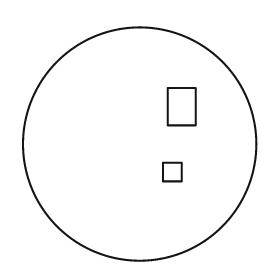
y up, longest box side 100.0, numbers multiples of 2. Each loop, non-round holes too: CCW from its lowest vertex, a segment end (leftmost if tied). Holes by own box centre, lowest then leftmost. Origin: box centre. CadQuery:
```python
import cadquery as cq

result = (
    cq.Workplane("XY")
    .moveTo(0.0, 0.0)
    .circle(50.0)
    .moveTo(10.0, -16.0)
    .lineTo(18.0, -16.0)
    .lineTo(18.0, -8.0)
    .lineTo(10.0, -8.0)
    .close()
    .moveTo(12.0, 8.0)
    .lineTo(24.0, 8.0)
    .lineTo(24.0, 24.0)
    .lineTo(12.0, 24.0)
    .close()
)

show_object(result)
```